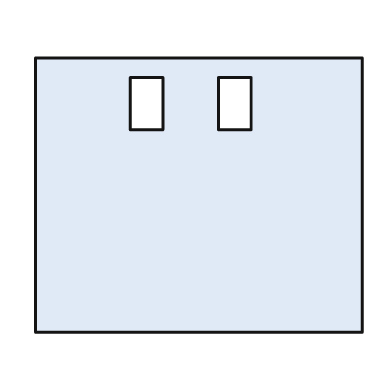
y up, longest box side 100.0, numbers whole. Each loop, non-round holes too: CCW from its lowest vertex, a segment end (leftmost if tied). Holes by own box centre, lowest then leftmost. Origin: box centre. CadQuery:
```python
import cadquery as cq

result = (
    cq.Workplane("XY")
    .moveTo(-50.0, -42.0)
    .lineTo(50.0, -42.0)
    .lineTo(50.0, 42.0)
    .lineTo(-50.0, 42.0)
    .close()
    .moveTo(-21.0, 20.0)
    .lineTo(-11.0, 20.0)
    .lineTo(-11.0, 36.0)
    .lineTo(-21.0, 36.0)
    .close()
    .moveTo(6.0, 20.0)
    .lineTo(16.0, 20.0)
    .lineTo(16.0, 36.0)
    .lineTo(6.0, 36.0)
    .close()
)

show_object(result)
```